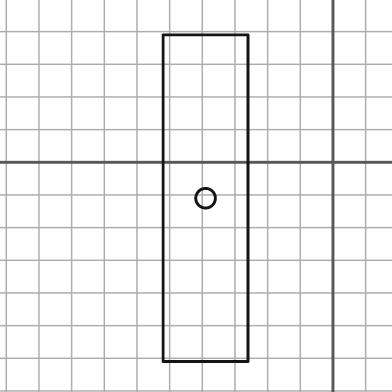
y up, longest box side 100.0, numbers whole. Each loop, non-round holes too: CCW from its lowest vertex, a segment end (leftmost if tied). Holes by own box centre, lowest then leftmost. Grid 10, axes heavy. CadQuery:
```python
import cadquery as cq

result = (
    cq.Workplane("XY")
    .moveTo(-52.0, -61.0)
    .lineTo(-26.0, -61.0)
    .lineTo(-26.0, 39.0)
    .lineTo(-52.0, 39.0)
    .close()
    .moveTo(-39.0, -11.0)
    .circle(3.0)
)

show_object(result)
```